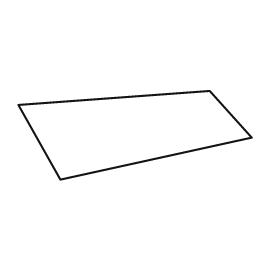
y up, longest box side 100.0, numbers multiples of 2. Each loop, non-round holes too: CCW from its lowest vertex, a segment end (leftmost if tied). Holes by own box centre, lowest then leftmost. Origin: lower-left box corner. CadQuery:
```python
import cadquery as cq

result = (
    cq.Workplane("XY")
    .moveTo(18.0, 0.0)
    .lineTo(100.0, 18.0)
    .lineTo(82.0, 38.0)
    .lineTo(0.0, 32.0)
    .close()
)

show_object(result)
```